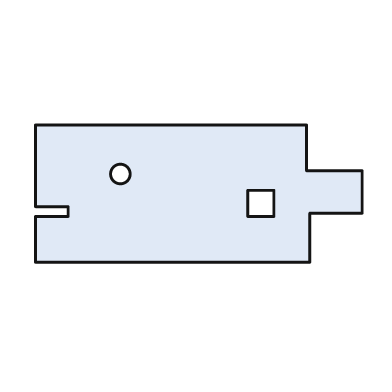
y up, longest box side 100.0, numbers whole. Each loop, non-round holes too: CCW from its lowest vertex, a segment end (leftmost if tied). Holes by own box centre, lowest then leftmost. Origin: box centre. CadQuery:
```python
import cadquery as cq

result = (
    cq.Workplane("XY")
    .moveTo(-50.0, -21.0)
    .lineTo(34.0, -21.0)
    .lineTo(34.0, -6.0)
    .lineTo(50.0, -6.0)
    .lineTo(50.0, 7.0)
    .lineTo(33.0, 7.0)
    .lineTo(33.0, 21.0)
    .lineTo(-50.0, 21.0)
    .lineTo(-50.0, -4.0)
    .lineTo(-40.0, -4.0)
    .lineTo(-40.0, -7.0)
    .lineTo(-50.0, -7.0)
    .close()
    .moveTo(15.0, -7.0)
    .lineTo(23.0, -7.0)
    .lineTo(23.0, 1.0)
    .lineTo(15.0, 1.0)
    .close()
    .moveTo(-24.0, 6.0)
    .circle(3.0)
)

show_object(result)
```